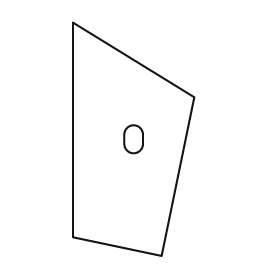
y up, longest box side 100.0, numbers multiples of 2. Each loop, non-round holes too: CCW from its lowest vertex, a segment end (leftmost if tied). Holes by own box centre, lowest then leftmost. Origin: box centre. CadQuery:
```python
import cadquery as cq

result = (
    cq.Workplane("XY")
    .moveTo(12.0, -50.0)
    .lineTo(26.0, 18.0)
    .lineTo(-26.0, 50.0)
    .lineTo(-26.0, -42.0)
    .close()
    .moveTo(-4.0, -2.0)
    .threePointArc((0.0, -6.0), (4.0, -2.0))
    .lineTo(4.0, 2.0)
    .threePointArc((0.0, 6.0), (-4.0, 2.0))
    .close()
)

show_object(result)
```